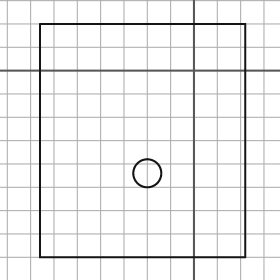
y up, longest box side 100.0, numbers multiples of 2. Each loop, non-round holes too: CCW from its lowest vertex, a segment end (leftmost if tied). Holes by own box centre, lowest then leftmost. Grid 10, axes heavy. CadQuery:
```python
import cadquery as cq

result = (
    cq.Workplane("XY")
    .moveTo(-66.0, -80.0)
    .lineTo(22.0, -80.0)
    .lineTo(22.0, 20.0)
    .lineTo(-66.0, 20.0)
    .close()
    .moveTo(-20.0, -44.0)
    .circle(6.0)
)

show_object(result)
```